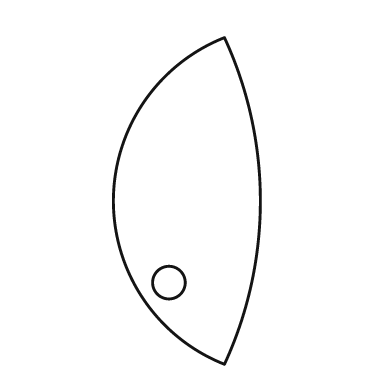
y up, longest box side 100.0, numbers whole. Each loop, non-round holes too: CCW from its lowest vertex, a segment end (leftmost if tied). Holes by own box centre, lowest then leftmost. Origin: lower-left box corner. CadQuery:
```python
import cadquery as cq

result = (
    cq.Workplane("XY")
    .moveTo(34.0, 0.0)
    .threePointArc((45.0, 50.0), (34.0, 100.0))
    .threePointArc((0.0, 50.0), (34.0, 0.0))
    .close()
    .moveTo(17.0, 25.0)
    .circle(5.0)
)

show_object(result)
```